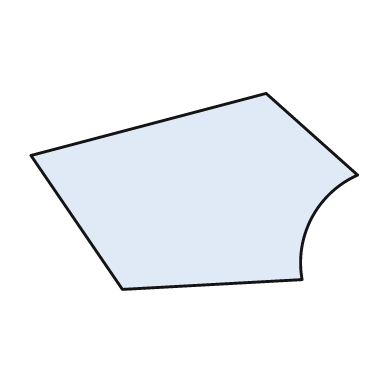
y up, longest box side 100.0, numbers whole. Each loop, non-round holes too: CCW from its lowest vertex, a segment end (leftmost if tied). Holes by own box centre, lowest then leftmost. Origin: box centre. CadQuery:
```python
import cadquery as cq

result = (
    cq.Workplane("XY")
    .moveTo(-22.0, -30.0)
    .lineTo(33.0, -27.0)
    .threePointArc((36.0, -8.0), (50.0, 5.0))
    .lineTo(22.0, 30.0)
    .lineTo(-50.0, 11.0)
    .close()
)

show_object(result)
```